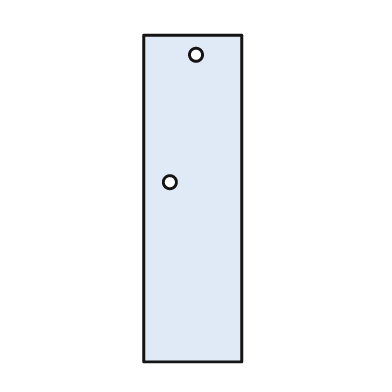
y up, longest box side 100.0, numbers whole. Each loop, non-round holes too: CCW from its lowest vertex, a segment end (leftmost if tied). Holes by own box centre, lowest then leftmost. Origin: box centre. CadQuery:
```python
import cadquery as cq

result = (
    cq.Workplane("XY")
    .moveTo(-15.0, -50.0)
    .lineTo(15.0, -50.0)
    .lineTo(15.0, 50.0)
    .lineTo(-15.0, 50.0)
    .close()
    .moveTo(-7.0, 5.0)
    .circle(2.0)
    .moveTo(1.0, 44.0)
    .circle(2.0)
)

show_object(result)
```